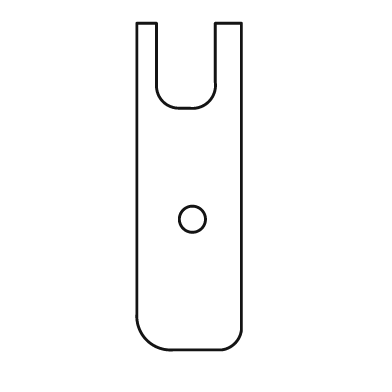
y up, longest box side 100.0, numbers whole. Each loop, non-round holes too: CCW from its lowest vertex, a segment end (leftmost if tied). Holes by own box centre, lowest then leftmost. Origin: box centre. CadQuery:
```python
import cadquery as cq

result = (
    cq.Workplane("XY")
    .moveTo(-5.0, -50.0)
    .lineTo(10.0, -50.0)
    .threePointArc((14.0, -48.0), (16.0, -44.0))
    .lineTo(16.0, 50.0)
    .lineTo(8.0, 50.0)
    .lineTo(8.0, 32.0)
    .threePointArc((6.0, 26.0), (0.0, 24.0))
    .lineTo(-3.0, 24.0)
    .threePointArc((-8.0, 26.0), (-10.0, 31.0))
    .lineTo(-10.0, 50.0)
    .lineTo(-16.0, 50.0)
    .lineTo(-16.0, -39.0)
    .threePointArc((-13.0, -47.0), (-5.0, -50.0))
    .close()
    .moveTo(1.0, -10.0)
    .circle(4.0)
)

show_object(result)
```